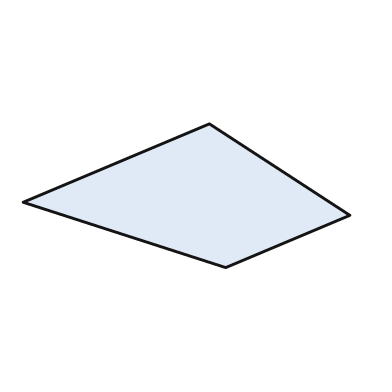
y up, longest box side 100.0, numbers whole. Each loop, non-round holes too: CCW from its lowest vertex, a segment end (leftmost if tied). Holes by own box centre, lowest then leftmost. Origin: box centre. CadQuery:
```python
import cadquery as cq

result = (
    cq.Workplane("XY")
    .moveTo(12.0, -22.0)
    .lineTo(50.0, -6.0)
    .lineTo(7.0, 22.0)
    .lineTo(-50.0, -2.0)
    .close()
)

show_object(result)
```